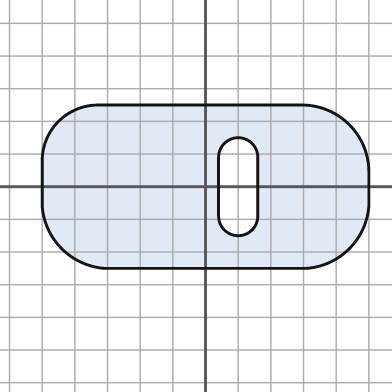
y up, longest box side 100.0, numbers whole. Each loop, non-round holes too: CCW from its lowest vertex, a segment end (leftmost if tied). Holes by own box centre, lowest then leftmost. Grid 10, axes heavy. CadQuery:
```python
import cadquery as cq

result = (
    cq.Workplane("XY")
    .moveTo(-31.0, -25.0)
    .lineTo(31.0, -25.0)
    .threePointArc((44.0, -19.0), (50.0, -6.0))
    .lineTo(50.0, 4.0)
    .threePointArc((44.0, 19.0), (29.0, 25.0))
    .lineTo(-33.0, 25.0)
    .threePointArc((-45.0, 20.0), (-50.0, 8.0))
    .lineTo(-50.0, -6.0)
    .threePointArc((-44.0, -19.0), (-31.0, -25.0))
    .close()
    .moveTo(4.0, -9.0)
    .threePointArc((10.0, -15.0), (16.0, -9.0))
    .lineTo(16.0, 9.0)
    .threePointArc((10.0, 15.0), (4.0, 9.0))
    .close()
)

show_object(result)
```